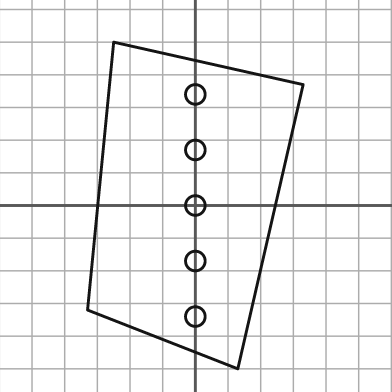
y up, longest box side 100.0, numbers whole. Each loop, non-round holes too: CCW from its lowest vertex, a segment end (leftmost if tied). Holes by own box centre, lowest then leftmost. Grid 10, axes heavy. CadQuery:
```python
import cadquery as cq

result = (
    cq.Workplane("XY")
    .moveTo(13.0, -50.0)
    .lineTo(33.0, 37.0)
    .lineTo(-25.0, 50.0)
    .lineTo(-33.0, -32.0)
    .close()
    .moveTo(0.0, -34.0)
    .circle(3.0)
    .moveTo(0.0, -17.0)
    .circle(3.0)
    .moveTo(0.0, 0.0)
    .circle(3.0)
    .moveTo(0.0, 17.0)
    .circle(3.0)
    .moveTo(0.0, 34.0)
    .circle(3.0)
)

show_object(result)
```